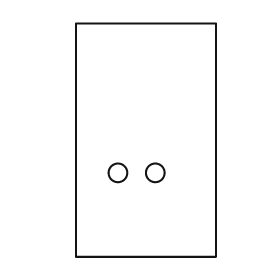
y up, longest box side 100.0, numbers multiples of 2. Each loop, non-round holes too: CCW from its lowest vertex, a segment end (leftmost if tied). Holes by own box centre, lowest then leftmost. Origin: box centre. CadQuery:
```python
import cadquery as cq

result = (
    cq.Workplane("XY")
    .moveTo(-30.0, -50.0)
    .lineTo(30.0, -50.0)
    .lineTo(30.0, 50.0)
    .lineTo(-30.0, 50.0)
    .close()
    .moveTo(-12.0, -14.0)
    .circle(4.0)
    .moveTo(4.0, -14.0)
    .circle(4.0)
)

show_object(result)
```